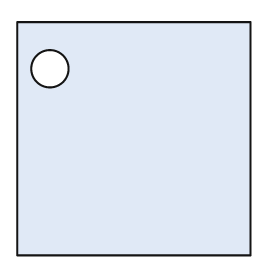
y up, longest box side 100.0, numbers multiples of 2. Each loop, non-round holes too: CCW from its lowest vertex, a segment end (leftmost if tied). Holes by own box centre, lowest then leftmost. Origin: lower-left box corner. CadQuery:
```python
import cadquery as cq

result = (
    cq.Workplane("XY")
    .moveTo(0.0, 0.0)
    .lineTo(100.0, 0.0)
    .lineTo(100.0, 100.0)
    .lineTo(0.0, 100.0)
    .close()
    .moveTo(14.0, 80.0)
    .circle(8.0)
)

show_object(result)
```